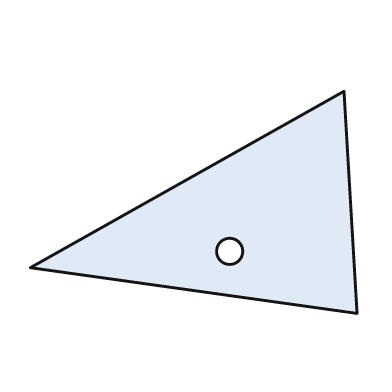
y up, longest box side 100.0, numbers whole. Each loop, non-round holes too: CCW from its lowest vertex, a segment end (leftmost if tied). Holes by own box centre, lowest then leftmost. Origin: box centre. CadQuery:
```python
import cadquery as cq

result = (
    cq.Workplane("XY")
    .moveTo(50.0, -34.0)
    .lineTo(46.0, 34.0)
    .lineTo(-50.0, -20.0)
    .close()
    .moveTo(11.0, -15.0)
    .circle(4.0)
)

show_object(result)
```